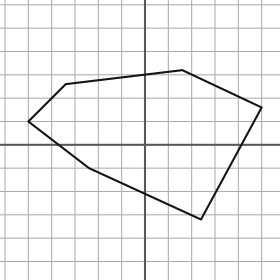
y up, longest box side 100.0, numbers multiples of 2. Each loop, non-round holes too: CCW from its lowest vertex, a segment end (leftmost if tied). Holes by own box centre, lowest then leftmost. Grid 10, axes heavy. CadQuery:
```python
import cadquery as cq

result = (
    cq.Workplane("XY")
    .moveTo(24.0, -32.0)
    .lineTo(50.0, 16.0)
    .lineTo(16.0, 32.0)
    .lineTo(-34.0, 26.0)
    .lineTo(-50.0, 10.0)
    .lineTo(-24.0, -10.0)
    .close()
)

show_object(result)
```